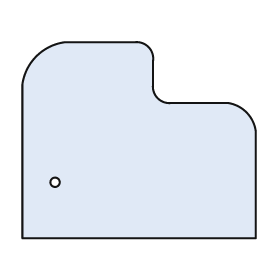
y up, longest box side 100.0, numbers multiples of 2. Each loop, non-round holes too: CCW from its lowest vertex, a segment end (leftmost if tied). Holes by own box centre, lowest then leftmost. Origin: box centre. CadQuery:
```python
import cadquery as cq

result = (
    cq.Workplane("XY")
    .moveTo(-50.0, -42.0)
    .lineTo(50.0, -42.0)
    .lineTo(50.0, 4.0)
    .threePointArc((46.0, 12.0), (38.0, 16.0))
    .lineTo(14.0, 16.0)
    .threePointArc((8.0, 18.0), (6.0, 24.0))
    .lineTo(6.0, 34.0)
    .threePointArc((4.0, 40.0), (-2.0, 42.0))
    .lineTo(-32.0, 42.0)
    .threePointArc((-44.0, 36.0), (-50.0, 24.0))
    .close()
    .moveTo(-36.0, -18.0)
    .circle(2.0)
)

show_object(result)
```